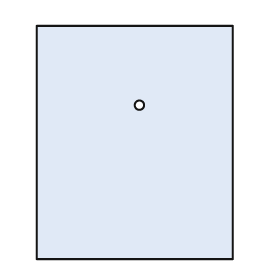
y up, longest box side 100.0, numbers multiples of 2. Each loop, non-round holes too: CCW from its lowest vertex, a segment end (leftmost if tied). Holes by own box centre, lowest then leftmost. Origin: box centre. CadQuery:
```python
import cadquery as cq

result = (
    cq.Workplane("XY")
    .moveTo(-42.0, -50.0)
    .lineTo(42.0, -50.0)
    .lineTo(42.0, 50.0)
    .lineTo(-42.0, 50.0)
    .close()
    .moveTo(2.0, 16.0)
    .circle(2.0)
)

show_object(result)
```